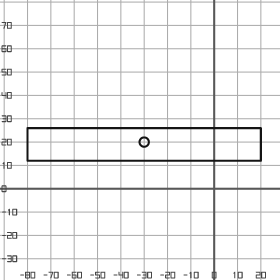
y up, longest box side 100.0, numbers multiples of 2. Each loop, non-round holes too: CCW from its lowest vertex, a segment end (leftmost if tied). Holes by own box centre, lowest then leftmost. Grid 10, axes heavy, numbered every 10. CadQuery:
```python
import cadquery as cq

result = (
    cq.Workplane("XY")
    .moveTo(-80.0, 12.0)
    .lineTo(20.0, 12.0)
    .lineTo(20.0, 26.0)
    .lineTo(-80.0, 26.0)
    .close()
    .moveTo(-30.0, 20.0)
    .circle(2.0)
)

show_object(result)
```